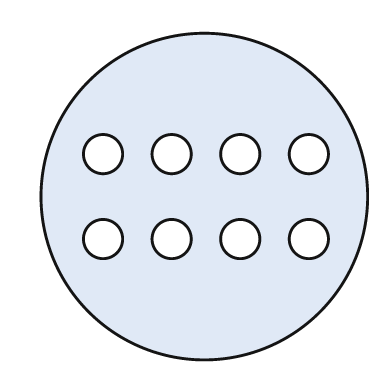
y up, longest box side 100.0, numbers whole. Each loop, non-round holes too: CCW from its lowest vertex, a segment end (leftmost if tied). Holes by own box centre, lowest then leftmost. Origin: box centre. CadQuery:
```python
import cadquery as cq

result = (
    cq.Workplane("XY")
    .moveTo(0.0, 0.0)
    .circle(50.0)
    .moveTo(-31.0, -13.0)
    .circle(6.0)
    .moveTo(-10.0, -13.0)
    .circle(6.0)
    .moveTo(11.0, -13.0)
    .circle(6.0)
    .moveTo(32.0, -13.0)
    .circle(6.0)
    .moveTo(-31.0, 13.0)
    .circle(6.0)
    .moveTo(-10.0, 13.0)
    .circle(6.0)
    .moveTo(11.0, 13.0)
    .circle(6.0)
    .moveTo(32.0, 13.0)
    .circle(6.0)
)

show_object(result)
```